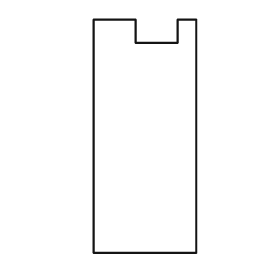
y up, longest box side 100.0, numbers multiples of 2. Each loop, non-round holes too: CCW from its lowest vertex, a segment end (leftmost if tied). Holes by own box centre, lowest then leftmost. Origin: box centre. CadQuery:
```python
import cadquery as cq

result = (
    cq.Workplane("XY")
    .moveTo(-22.0, -50.0)
    .lineTo(22.0, -50.0)
    .lineTo(22.0, 50.0)
    .lineTo(14.0, 50.0)
    .lineTo(14.0, 40.0)
    .lineTo(-4.0, 40.0)
    .lineTo(-4.0, 50.0)
    .lineTo(-22.0, 50.0)
    .close()
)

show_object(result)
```